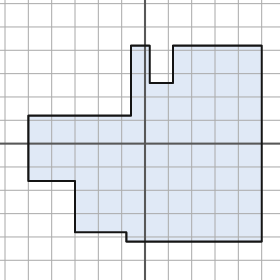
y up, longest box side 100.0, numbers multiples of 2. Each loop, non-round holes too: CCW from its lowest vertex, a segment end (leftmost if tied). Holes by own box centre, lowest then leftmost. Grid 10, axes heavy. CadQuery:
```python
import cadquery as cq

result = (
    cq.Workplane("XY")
    .moveTo(-8.0, -42.0)
    .lineTo(50.0, -42.0)
    .lineTo(50.0, 42.0)
    .lineTo(12.0, 42.0)
    .lineTo(12.0, 26.0)
    .lineTo(2.0, 26.0)
    .lineTo(2.0, 42.0)
    .lineTo(-6.0, 42.0)
    .lineTo(-6.0, 12.0)
    .lineTo(-50.0, 12.0)
    .lineTo(-50.0, -16.0)
    .lineTo(-30.0, -16.0)
    .lineTo(-30.0, -38.0)
    .lineTo(-8.0, -38.0)
    .close()
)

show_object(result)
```